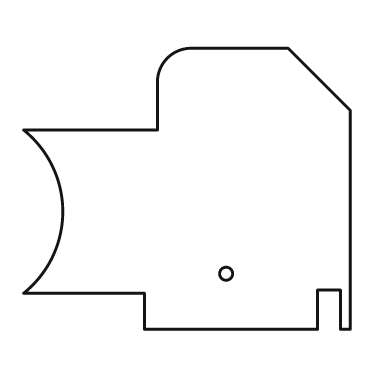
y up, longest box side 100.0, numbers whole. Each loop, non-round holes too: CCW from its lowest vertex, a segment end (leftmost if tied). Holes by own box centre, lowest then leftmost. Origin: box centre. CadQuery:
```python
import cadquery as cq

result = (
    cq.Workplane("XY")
    .moveTo(-13.0, -43.0)
    .lineTo(40.0, -43.0)
    .lineTo(40.0, -31.0)
    .lineTo(47.0, -31.0)
    .lineTo(47.0, -43.0)
    .lineTo(50.0, -43.0)
    .lineTo(50.0, 24.0)
    .lineTo(31.0, 43.0)
    .lineTo(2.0, 43.0)
    .threePointArc((-6.0, 40.0), (-9.0, 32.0))
    .lineTo(-9.0, 18.0)
    .lineTo(-50.0, 18.0)
    .threePointArc((-38.0, -7.0), (-50.0, -32.0))
    .lineTo(-13.0, -32.0)
    .close()
    .moveTo(12.0, -26.0)
    .circle(2.0)
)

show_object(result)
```